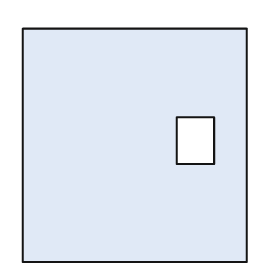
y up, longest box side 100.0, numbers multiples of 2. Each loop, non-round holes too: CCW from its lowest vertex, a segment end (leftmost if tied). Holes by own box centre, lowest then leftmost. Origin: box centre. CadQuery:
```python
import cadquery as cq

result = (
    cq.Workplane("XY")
    .moveTo(-48.0, -50.0)
    .lineTo(48.0, -50.0)
    .lineTo(48.0, 50.0)
    .lineTo(-48.0, 50.0)
    .close()
    .moveTo(18.0, -8.0)
    .lineTo(34.0, -8.0)
    .lineTo(34.0, 12.0)
    .lineTo(18.0, 12.0)
    .close()
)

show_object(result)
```